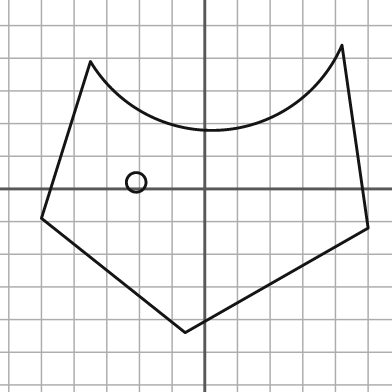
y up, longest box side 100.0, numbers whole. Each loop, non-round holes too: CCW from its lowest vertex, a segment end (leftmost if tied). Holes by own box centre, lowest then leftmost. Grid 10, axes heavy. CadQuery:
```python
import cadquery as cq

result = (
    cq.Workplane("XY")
    .moveTo(-6.0, -44.0)
    .lineTo(50.0, -12.0)
    .lineTo(42.0, 44.0)
    .threePointArc((5.0, 18.0), (-35.0, 39.0))
    .lineTo(-50.0, -9.0)
    .close()
    .moveTo(-21.0, 2.0)
    .circle(3.0)
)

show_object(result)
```